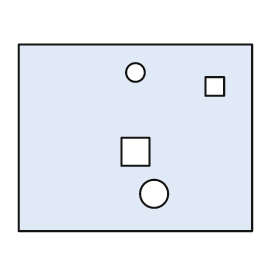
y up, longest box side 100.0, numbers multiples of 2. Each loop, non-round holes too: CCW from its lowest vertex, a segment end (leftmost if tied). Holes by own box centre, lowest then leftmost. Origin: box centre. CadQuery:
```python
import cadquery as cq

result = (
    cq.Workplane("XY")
    .moveTo(-50.0, -40.0)
    .lineTo(50.0, -40.0)
    .lineTo(50.0, 40.0)
    .lineTo(-50.0, 40.0)
    .close()
    .moveTo(8.0, -24.0)
    .circle(6.0)
    .moveTo(-6.0, -12.0)
    .lineTo(6.0, -12.0)
    .lineTo(6.0, 0.0)
    .lineTo(-6.0, 0.0)
    .close()
    .moveTo(30.0, 18.0)
    .lineTo(38.0, 18.0)
    .lineTo(38.0, 26.0)
    .lineTo(30.0, 26.0)
    .close()
    .moveTo(0.0, 28.0)
    .circle(4.0)
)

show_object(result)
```